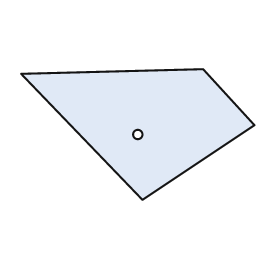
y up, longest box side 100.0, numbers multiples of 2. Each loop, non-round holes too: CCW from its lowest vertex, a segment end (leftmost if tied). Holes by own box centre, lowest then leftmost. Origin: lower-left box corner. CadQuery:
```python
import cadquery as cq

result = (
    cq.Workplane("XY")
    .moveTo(52.0, 0.0)
    .lineTo(100.0, 32.0)
    .lineTo(78.0, 56.0)
    .lineTo(0.0, 54.0)
    .close()
    .moveTo(50.0, 28.0)
    .circle(2.0)
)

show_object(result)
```